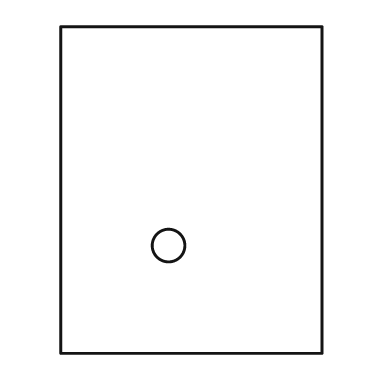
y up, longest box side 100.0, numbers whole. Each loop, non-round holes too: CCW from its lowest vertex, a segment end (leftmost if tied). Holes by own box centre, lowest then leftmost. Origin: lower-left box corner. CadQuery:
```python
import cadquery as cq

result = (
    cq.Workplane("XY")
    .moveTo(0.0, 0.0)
    .lineTo(80.0, 0.0)
    .lineTo(80.0, 100.0)
    .lineTo(0.0, 100.0)
    .close()
    .moveTo(33.0, 33.0)
    .circle(5.0)
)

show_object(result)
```